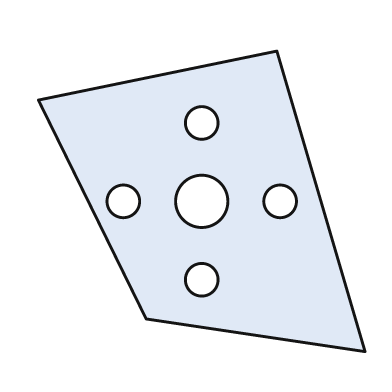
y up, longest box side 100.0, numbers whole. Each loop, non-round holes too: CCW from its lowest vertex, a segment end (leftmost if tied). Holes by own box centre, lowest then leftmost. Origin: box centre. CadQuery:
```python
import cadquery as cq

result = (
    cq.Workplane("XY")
    .moveTo(50.0, -46.0)
    .lineTo(23.0, 46.0)
    .lineTo(-50.0, 31.0)
    .lineTo(-17.0, -36.0)
    .close()
    .moveTo(0.0, -24.0)
    .circle(5.0)
    .moveTo(-24.0, 0.0)
    .circle(5.0)
    .moveTo(0.0, 0.0)
    .circle(8.0)
    .moveTo(24.0, 0.0)
    .circle(5.0)
    .moveTo(0.0, 24.0)
    .circle(5.0)
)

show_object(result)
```